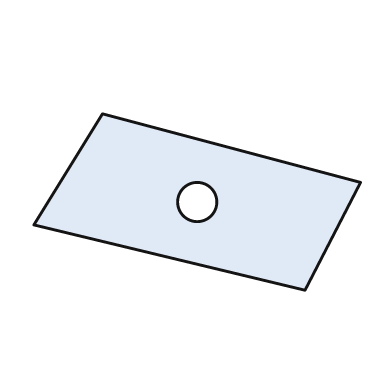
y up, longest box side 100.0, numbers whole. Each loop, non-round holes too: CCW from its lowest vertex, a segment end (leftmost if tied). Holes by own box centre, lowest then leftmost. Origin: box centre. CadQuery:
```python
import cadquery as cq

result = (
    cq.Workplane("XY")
    .moveTo(33.0, -27.0)
    .lineTo(50.0, 6.0)
    .lineTo(-29.0, 27.0)
    .lineTo(-50.0, -7.0)
    .close()
    .moveTo(0.0, 0.0)
    .circle(6.0)
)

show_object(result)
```